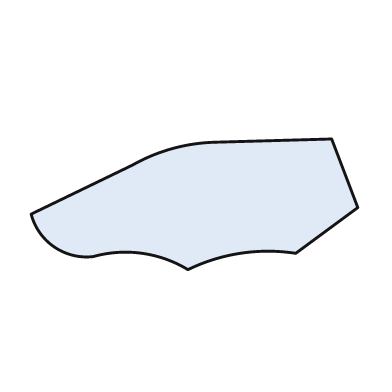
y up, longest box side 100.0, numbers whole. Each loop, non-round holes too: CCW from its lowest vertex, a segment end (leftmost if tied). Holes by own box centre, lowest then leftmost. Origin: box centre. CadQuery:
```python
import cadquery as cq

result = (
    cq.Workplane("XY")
    .moveTo(-2.0, -20.0)
    .threePointArc((14.0, -15.0), (31.0, -15.0))
    .lineTo(50.0, -1.0)
    .lineTo(42.0, 20.0)
    .lineTo(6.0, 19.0)
    .threePointArc((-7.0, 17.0), (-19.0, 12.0))
    .lineTo(-50.0, -3.0)
    .threePointArc((-43.0, -13.0), (-31.0, -16.0))
    .threePointArc((-16.0, -15.0), (-2.0, -20.0))
    .close()
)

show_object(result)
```